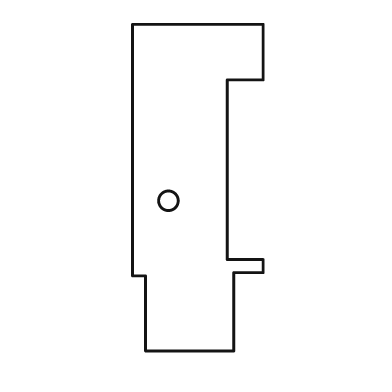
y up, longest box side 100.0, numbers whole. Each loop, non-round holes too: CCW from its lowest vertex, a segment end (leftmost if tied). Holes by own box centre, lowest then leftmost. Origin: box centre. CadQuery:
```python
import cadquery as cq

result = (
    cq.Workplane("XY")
    .moveTo(-16.0, -50.0)
    .lineTo(11.0, -50.0)
    .lineTo(11.0, -26.0)
    .lineTo(20.0, -26.0)
    .lineTo(20.0, -22.0)
    .lineTo(9.0, -22.0)
    .lineTo(9.0, 33.0)
    .lineTo(20.0, 33.0)
    .lineTo(20.0, 50.0)
    .lineTo(-20.0, 50.0)
    .lineTo(-20.0, -27.0)
    .lineTo(-16.0, -27.0)
    .close()
    .moveTo(-9.0, -4.0)
    .circle(3.0)
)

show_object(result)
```